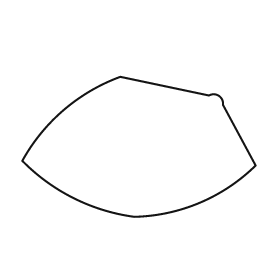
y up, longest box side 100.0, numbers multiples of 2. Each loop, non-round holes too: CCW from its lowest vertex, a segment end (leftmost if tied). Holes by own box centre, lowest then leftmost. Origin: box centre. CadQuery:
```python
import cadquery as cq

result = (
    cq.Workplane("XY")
    .moveTo(-2.0, -30.0)
    .threePointArc((26.0, -24.0), (50.0, -8.0))
    .lineTo(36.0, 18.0)
    .threePointArc((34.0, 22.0), (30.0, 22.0))
    .lineTo(-8.0, 30.0)
    .threePointArc((-32.0, 16.0), (-50.0, -6.0))
    .threePointArc((-28.0, -22.0), (-2.0, -30.0))
    .close()
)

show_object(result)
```